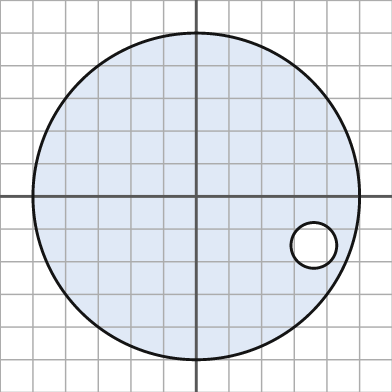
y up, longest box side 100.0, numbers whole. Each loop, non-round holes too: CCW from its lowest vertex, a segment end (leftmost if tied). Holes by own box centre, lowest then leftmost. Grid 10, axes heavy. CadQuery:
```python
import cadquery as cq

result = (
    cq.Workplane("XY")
    .moveTo(0.0, 0.0)
    .circle(50.0)
    .moveTo(36.0, -15.0)
    .circle(7.0)
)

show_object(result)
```